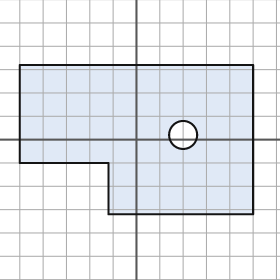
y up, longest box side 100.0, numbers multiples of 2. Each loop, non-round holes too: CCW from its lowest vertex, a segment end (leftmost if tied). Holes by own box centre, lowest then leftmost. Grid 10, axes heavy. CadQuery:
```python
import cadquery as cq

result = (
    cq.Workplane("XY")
    .moveTo(-12.0, -32.0)
    .lineTo(50.0, -32.0)
    .lineTo(50.0, 32.0)
    .lineTo(-50.0, 32.0)
    .lineTo(-50.0, -10.0)
    .lineTo(-12.0, -10.0)
    .close()
    .moveTo(20.0, 2.0)
    .circle(6.0)
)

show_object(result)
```